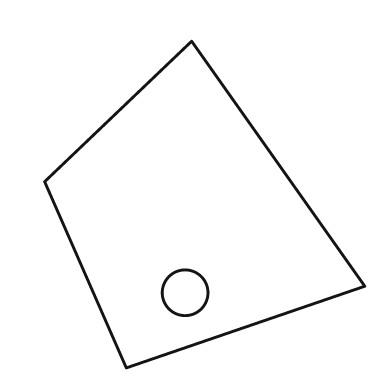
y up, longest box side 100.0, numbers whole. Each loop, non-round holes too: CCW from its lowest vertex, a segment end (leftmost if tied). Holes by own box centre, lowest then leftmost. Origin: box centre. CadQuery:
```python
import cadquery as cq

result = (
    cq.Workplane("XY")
    .moveTo(-24.0, -50.0)
    .lineTo(49.0, -25.0)
    .lineTo(-4.0, 50.0)
    .lineTo(-49.0, 7.0)
    .close()
    .moveTo(-6.0, -27.0)
    .circle(7.0)
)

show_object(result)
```